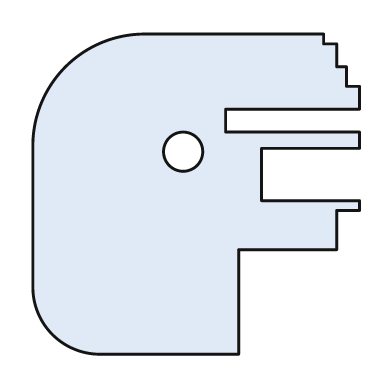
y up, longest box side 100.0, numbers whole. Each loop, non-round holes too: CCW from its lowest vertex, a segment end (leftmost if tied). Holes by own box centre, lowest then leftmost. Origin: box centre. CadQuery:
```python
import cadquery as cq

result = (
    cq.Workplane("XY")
    .moveTo(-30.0, -49.0)
    .lineTo(13.0, -49.0)
    .lineTo(13.0, -17.0)
    .lineTo(43.0, -17.0)
    .lineTo(43.0, -5.0)
    .lineTo(50.0, -5.0)
    .lineTo(50.0, -2.0)
    .lineTo(20.0, -2.0)
    .lineTo(20.0, 14.0)
    .lineTo(50.0, 14.0)
    .lineTo(50.0, 19.0)
    .lineTo(9.0, 19.0)
    .lineTo(9.0, 26.0)
    .lineTo(50.0, 26.0)
    .lineTo(50.0, 33.0)
    .lineTo(46.0, 33.0)
    .lineTo(46.0, 39.0)
    .lineTo(43.0, 39.0)
    .lineTo(43.0, 46.0)
    .lineTo(39.0, 46.0)
    .lineTo(39.0, 49.0)
    .lineTo(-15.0, 49.0)
    .threePointArc((-40.0, 39.0), (-50.0, 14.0))
    .lineTo(-50.0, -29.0)
    .threePointArc((-44.0, -43.0), (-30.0, -49.0))
    .close()
    .moveTo(-4.0, 13.0)
    .circle(6.0)
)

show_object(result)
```